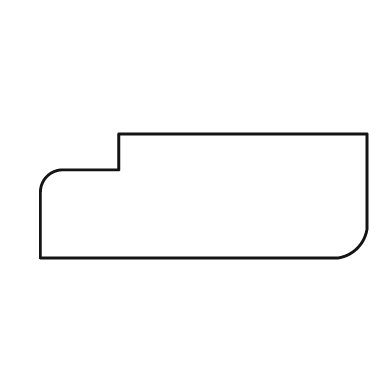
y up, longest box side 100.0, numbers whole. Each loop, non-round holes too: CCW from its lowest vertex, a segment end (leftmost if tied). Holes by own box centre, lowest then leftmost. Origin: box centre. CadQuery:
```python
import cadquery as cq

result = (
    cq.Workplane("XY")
    .moveTo(-50.0, -19.0)
    .lineTo(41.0, -19.0)
    .threePointArc((47.0, -16.0), (50.0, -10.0))
    .lineTo(50.0, 19.0)
    .lineTo(-26.0, 19.0)
    .lineTo(-26.0, 8.0)
    .lineTo(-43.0, 8.0)
    .threePointArc((-48.0, 6.0), (-50.0, 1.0))
    .close()
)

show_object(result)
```